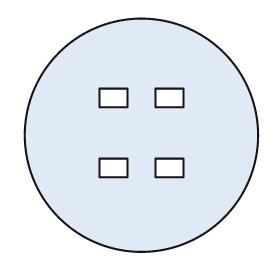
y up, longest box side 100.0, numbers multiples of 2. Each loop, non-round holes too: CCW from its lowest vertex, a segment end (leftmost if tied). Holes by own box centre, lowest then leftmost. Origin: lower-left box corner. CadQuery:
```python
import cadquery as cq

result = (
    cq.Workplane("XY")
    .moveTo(50.0, 50.0)
    .circle(50.0)
    .moveTo(32.0, 32.0)
    .lineTo(44.0, 32.0)
    .lineTo(44.0, 40.0)
    .lineTo(32.0, 40.0)
    .close()
    .moveTo(56.0, 32.0)
    .lineTo(68.0, 32.0)
    .lineTo(68.0, 40.0)
    .lineTo(56.0, 40.0)
    .close()
    .moveTo(32.0, 62.0)
    .lineTo(44.0, 62.0)
    .lineTo(44.0, 70.0)
    .lineTo(32.0, 70.0)
    .close()
    .moveTo(56.0, 62.0)
    .lineTo(68.0, 62.0)
    .lineTo(68.0, 70.0)
    .lineTo(56.0, 70.0)
    .close()
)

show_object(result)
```